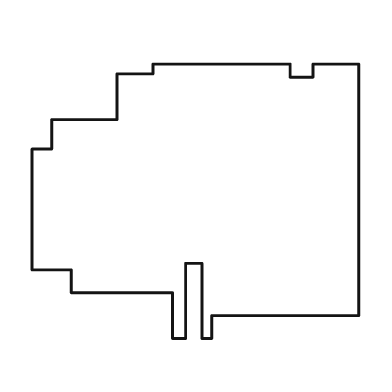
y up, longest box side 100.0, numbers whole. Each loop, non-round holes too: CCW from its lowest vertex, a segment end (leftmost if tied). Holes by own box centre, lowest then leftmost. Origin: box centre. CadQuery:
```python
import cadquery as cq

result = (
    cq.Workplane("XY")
    .moveTo(-7.0, -42.0)
    .lineTo(-3.0, -42.0)
    .lineTo(-3.0, -19.0)
    .lineTo(2.0, -19.0)
    .lineTo(2.0, -42.0)
    .lineTo(5.0, -42.0)
    .lineTo(5.0, -35.0)
    .lineTo(50.0, -35.0)
    .lineTo(50.0, 42.0)
    .lineTo(36.0, 42.0)
    .lineTo(36.0, 38.0)
    .lineTo(29.0, 38.0)
    .lineTo(29.0, 42.0)
    .lineTo(-13.0, 42.0)
    .lineTo(-13.0, 39.0)
    .lineTo(-24.0, 39.0)
    .lineTo(-24.0, 25.0)
    .lineTo(-44.0, 25.0)
    .lineTo(-44.0, 16.0)
    .lineTo(-50.0, 16.0)
    .lineTo(-50.0, -21.0)
    .lineTo(-38.0, -21.0)
    .lineTo(-38.0, -28.0)
    .lineTo(-7.0, -28.0)
    .close()
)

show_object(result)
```